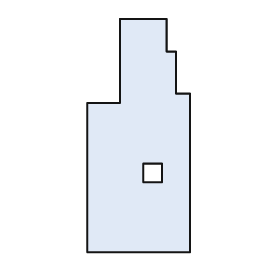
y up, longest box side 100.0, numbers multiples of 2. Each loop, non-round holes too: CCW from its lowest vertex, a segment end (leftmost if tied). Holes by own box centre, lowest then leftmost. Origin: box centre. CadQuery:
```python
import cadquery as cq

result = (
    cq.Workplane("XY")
    .moveTo(-22.0, -50.0)
    .lineTo(22.0, -50.0)
    .lineTo(22.0, 18.0)
    .lineTo(16.0, 18.0)
    .lineTo(16.0, 36.0)
    .lineTo(12.0, 36.0)
    .lineTo(12.0, 50.0)
    .lineTo(-8.0, 50.0)
    .lineTo(-8.0, 14.0)
    .lineTo(-22.0, 14.0)
    .close()
    .moveTo(2.0, -20.0)
    .lineTo(10.0, -20.0)
    .lineTo(10.0, -12.0)
    .lineTo(2.0, -12.0)
    .close()
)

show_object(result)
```